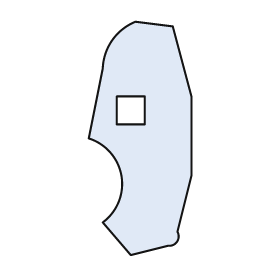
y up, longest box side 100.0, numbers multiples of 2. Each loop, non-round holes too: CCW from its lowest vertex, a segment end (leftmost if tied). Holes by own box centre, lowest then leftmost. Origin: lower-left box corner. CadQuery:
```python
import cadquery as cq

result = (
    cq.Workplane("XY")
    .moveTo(18.0, 0.0)
    .lineTo(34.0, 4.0)
    .threePointArc((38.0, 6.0), (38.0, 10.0))
    .lineTo(44.0, 34.0)
    .lineTo(44.0, 68.0)
    .lineTo(36.0, 98.0)
    .lineTo(20.0, 100.0)
    .threePointArc((10.0, 92.0), (6.0, 80.0))
    .lineTo(0.0, 50.0)
    .threePointArc((14.0, 34.0), (6.0, 14.0))
    .close()
    .moveTo(12.0, 56.0)
    .lineTo(24.0, 56.0)
    .lineTo(24.0, 68.0)
    .lineTo(12.0, 68.0)
    .close()
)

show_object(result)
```